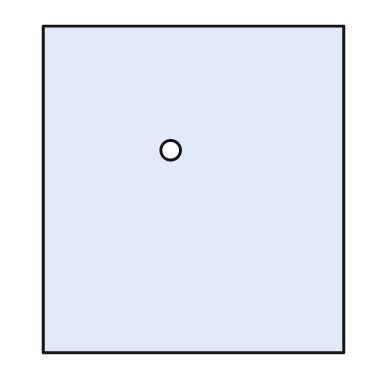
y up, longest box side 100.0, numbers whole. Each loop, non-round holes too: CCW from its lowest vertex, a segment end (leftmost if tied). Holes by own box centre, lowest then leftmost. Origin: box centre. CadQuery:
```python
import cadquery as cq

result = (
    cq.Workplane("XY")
    .moveTo(-46.0, -50.0)
    .lineTo(46.0, -50.0)
    .lineTo(46.0, 50.0)
    .lineTo(-46.0, 50.0)
    .close()
    .moveTo(-7.0, 12.0)
    .circle(3.0)
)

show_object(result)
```